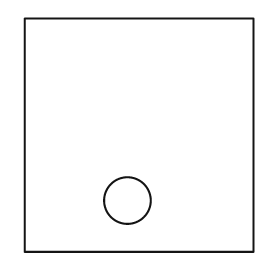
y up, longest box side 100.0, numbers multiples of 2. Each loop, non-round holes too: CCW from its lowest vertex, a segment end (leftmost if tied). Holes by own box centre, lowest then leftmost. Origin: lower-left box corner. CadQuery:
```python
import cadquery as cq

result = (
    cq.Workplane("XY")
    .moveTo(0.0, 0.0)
    .lineTo(98.0, 0.0)
    .lineTo(98.0, 100.0)
    .lineTo(0.0, 100.0)
    .close()
    .moveTo(44.0, 22.0)
    .circle(10.0)
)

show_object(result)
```